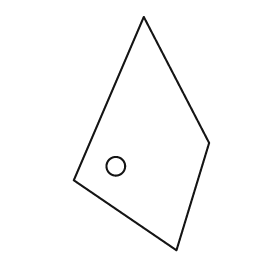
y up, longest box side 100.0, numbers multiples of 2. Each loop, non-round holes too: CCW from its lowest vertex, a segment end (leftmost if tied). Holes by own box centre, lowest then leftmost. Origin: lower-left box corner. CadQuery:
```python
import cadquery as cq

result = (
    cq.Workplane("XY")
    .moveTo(44.0, 0.0)
    .lineTo(58.0, 46.0)
    .lineTo(30.0, 100.0)
    .lineTo(0.0, 30.0)
    .close()
    .moveTo(18.0, 36.0)
    .circle(4.0)
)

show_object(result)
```